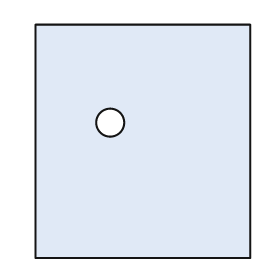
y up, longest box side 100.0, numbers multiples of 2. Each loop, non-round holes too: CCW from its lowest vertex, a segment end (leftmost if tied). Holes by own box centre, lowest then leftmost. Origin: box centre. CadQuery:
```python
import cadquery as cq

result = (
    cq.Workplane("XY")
    .moveTo(-46.0, -50.0)
    .lineTo(46.0, -50.0)
    .lineTo(46.0, 50.0)
    .lineTo(-46.0, 50.0)
    .close()
    .moveTo(-14.0, 8.0)
    .circle(6.0)
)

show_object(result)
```